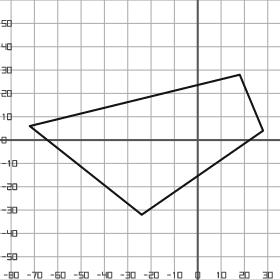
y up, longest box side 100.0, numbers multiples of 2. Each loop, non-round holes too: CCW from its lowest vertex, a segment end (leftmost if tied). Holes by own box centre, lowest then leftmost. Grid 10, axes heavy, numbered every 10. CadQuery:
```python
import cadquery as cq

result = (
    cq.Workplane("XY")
    .moveTo(-24.0, -32.0)
    .lineTo(28.0, 4.0)
    .lineTo(18.0, 28.0)
    .lineTo(-72.0, 6.0)
    .close()
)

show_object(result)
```